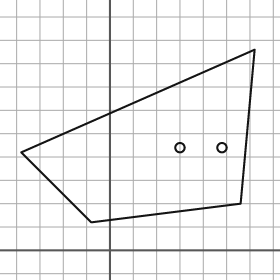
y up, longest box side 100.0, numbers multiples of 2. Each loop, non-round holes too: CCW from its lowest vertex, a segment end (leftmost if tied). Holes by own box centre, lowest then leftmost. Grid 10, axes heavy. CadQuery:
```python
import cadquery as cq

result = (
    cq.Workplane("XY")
    .moveTo(-8.0, 12.0)
    .lineTo(56.0, 20.0)
    .lineTo(62.0, 86.0)
    .lineTo(-38.0, 42.0)
    .close()
    .moveTo(30.0, 44.0)
    .circle(2.0)
    .moveTo(48.0, 44.0)
    .circle(2.0)
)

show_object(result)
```